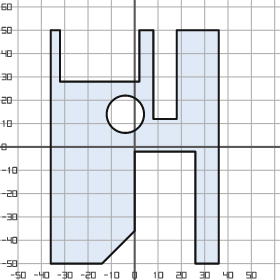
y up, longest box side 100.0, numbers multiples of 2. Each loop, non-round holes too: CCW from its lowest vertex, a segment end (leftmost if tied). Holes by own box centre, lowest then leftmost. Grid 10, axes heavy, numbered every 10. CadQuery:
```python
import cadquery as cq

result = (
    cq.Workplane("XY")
    .moveTo(-36.0, -50.0)
    .lineTo(-14.0, -50.0)
    .lineTo(0.0, -36.0)
    .lineTo(0.0, -2.0)
    .lineTo(26.0, -2.0)
    .lineTo(26.0, -50.0)
    .lineTo(36.0, -50.0)
    .lineTo(36.0, 50.0)
    .lineTo(18.0, 50.0)
    .lineTo(18.0, 12.0)
    .lineTo(8.0, 12.0)
    .lineTo(8.0, 50.0)
    .lineTo(2.0, 50.0)
    .lineTo(2.0, 28.0)
    .lineTo(-32.0, 28.0)
    .lineTo(-32.0, 50.0)
    .lineTo(-36.0, 50.0)
    .close()
    .moveTo(-4.0, 14.0)
    .circle(8.0)
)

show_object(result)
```